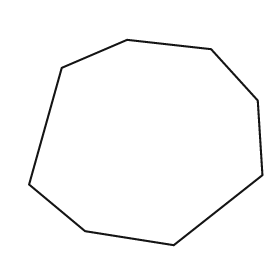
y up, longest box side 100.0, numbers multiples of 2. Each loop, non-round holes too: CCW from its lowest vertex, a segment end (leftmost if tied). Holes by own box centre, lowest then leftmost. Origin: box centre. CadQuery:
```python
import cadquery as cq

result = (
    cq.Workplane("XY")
    .moveTo(12.0, -44.0)
    .lineTo(50.0, -14.0)
    .lineTo(48.0, 18.0)
    .lineTo(28.0, 40.0)
    .lineTo(-8.0, 44.0)
    .lineTo(-36.0, 32.0)
    .lineTo(-50.0, -18.0)
    .lineTo(-26.0, -38.0)
    .close()
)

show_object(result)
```